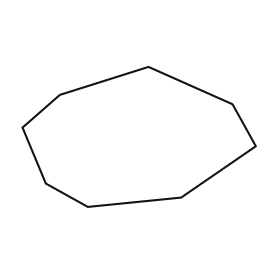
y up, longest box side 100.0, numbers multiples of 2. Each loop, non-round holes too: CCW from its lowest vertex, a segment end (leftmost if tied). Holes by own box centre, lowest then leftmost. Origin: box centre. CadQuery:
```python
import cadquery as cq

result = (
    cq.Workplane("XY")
    .moveTo(-22.0, -30.0)
    .lineTo(18.0, -26.0)
    .lineTo(50.0, -4.0)
    .lineTo(40.0, 14.0)
    .lineTo(4.0, 30.0)
    .lineTo(-34.0, 18.0)
    .lineTo(-50.0, 4.0)
    .lineTo(-40.0, -20.0)
    .close()
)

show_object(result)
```